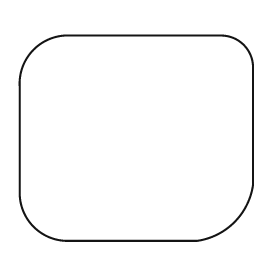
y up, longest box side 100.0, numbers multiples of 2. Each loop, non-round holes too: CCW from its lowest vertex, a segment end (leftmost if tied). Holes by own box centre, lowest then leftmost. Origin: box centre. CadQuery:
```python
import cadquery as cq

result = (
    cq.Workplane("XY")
    .moveTo(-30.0, -44.0)
    .lineTo(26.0, -44.0)
    .threePointArc((42.0, -36.0), (50.0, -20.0))
    .lineTo(50.0, 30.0)
    .threePointArc((46.0, 40.0), (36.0, 44.0))
    .lineTo(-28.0, 44.0)
    .threePointArc((-44.0, 38.0), (-50.0, 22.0))
    .lineTo(-50.0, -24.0)
    .threePointArc((-44.0, -38.0), (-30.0, -44.0))
    .close()
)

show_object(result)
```